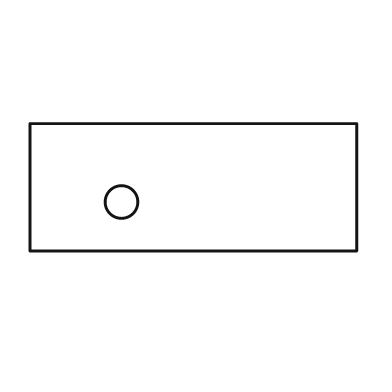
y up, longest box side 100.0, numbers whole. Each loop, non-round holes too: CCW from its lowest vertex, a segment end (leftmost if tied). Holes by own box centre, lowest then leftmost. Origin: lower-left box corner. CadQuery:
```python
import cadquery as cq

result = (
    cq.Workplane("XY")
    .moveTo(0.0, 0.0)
    .lineTo(100.0, 0.0)
    .lineTo(100.0, 39.0)
    .lineTo(0.0, 39.0)
    .close()
    .moveTo(28.0, 15.0)
    .circle(5.0)
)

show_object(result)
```